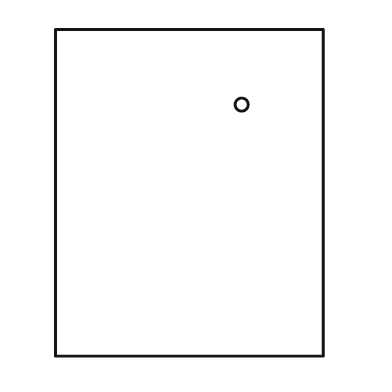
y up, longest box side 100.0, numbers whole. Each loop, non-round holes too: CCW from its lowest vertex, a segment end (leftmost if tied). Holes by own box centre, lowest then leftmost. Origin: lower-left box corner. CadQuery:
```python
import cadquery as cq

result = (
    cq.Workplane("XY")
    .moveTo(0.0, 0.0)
    .lineTo(82.0, 0.0)
    .lineTo(82.0, 100.0)
    .lineTo(0.0, 100.0)
    .close()
    .moveTo(57.0, 77.0)
    .circle(2.0)
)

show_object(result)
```